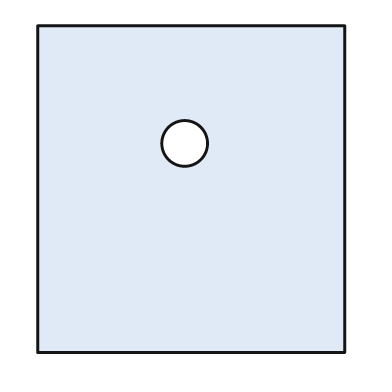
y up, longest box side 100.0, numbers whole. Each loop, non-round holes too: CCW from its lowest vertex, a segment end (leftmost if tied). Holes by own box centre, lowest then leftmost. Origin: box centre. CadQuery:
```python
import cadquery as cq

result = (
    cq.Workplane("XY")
    .moveTo(-47.0, -50.0)
    .lineTo(47.0, -50.0)
    .lineTo(47.0, 50.0)
    .lineTo(-47.0, 50.0)
    .close()
    .moveTo(-2.0, 14.0)
    .circle(7.0)
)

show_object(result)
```